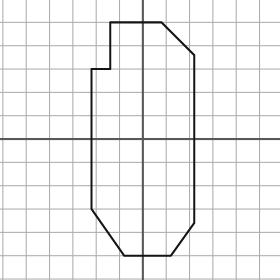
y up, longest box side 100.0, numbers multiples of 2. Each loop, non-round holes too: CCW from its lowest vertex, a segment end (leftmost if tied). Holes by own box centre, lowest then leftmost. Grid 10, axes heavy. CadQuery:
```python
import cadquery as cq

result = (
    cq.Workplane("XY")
    .moveTo(-8.0, -50.0)
    .lineTo(12.0, -50.0)
    .lineTo(22.0, -36.0)
    .lineTo(22.0, 36.0)
    .lineTo(8.0, 50.0)
    .lineTo(-14.0, 50.0)
    .lineTo(-14.0, 30.0)
    .lineTo(-22.0, 30.0)
    .lineTo(-22.0, -30.0)
    .close()
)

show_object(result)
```